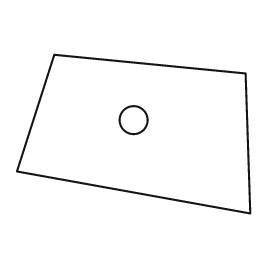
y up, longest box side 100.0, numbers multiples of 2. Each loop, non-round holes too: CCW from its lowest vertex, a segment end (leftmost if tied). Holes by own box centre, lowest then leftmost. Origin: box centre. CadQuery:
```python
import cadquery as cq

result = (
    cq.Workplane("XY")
    .moveTo(50.0, -34.0)
    .lineTo(48.0, 26.0)
    .lineTo(-34.0, 34.0)
    .lineTo(-50.0, -16.0)
    .close()
    .moveTo(0.0, 6.0)
    .circle(6.0)
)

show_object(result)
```